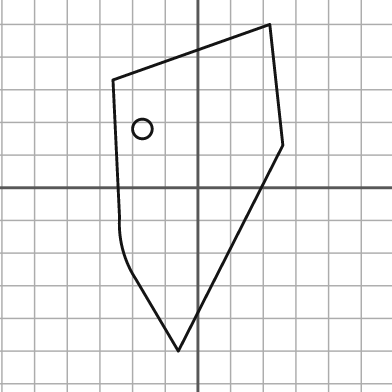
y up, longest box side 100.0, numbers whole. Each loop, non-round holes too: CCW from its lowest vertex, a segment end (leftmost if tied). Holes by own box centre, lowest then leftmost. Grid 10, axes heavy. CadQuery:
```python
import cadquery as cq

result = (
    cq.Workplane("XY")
    .moveTo(-6.0, -50.0)
    .lineTo(26.0, 13.0)
    .lineTo(22.0, 50.0)
    .lineTo(-26.0, 33.0)
    .lineTo(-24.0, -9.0)
    .threePointArc((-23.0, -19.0), (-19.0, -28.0))
    .close()
    .moveTo(-17.0, 18.0)
    .circle(3.0)
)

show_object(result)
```